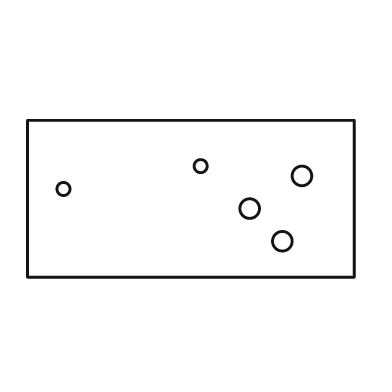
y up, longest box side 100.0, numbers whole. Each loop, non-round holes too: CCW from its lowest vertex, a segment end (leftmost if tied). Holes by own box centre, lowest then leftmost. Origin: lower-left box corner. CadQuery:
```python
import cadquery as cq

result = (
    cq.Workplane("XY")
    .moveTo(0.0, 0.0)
    .lineTo(100.0, 0.0)
    .lineTo(100.0, 48.0)
    .lineTo(0.0, 48.0)
    .close()
    .moveTo(78.0, 11.0)
    .circle(3.0)
    .moveTo(68.0, 21.0)
    .circle(3.0)
    .moveTo(11.0, 27.0)
    .circle(2.0)
    .moveTo(84.0, 31.0)
    .circle(3.0)
    .moveTo(53.0, 34.0)
    .circle(2.0)
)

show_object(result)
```